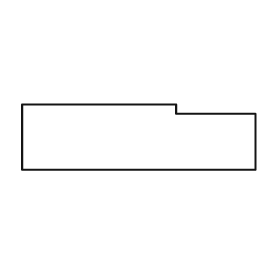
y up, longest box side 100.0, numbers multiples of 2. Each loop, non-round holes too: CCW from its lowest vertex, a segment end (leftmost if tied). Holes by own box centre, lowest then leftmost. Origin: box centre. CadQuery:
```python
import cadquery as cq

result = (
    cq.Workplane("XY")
    .moveTo(-50.0, -14.0)
    .lineTo(50.0, -14.0)
    .lineTo(50.0, 10.0)
    .lineTo(16.0, 10.0)
    .lineTo(16.0, 14.0)
    .lineTo(-50.0, 14.0)
    .close()
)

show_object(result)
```